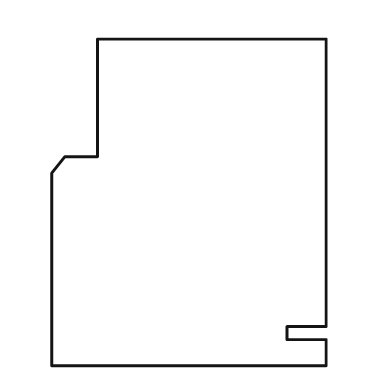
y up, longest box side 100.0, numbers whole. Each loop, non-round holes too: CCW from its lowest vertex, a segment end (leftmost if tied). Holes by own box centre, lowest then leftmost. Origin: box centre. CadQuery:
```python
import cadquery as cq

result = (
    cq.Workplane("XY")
    .moveTo(-42.0, -50.0)
    .lineTo(42.0, -50.0)
    .lineTo(42.0, -42.0)
    .lineTo(30.0, -42.0)
    .lineTo(30.0, -38.0)
    .lineTo(42.0, -38.0)
    .lineTo(42.0, 50.0)
    .lineTo(-28.0, 50.0)
    .lineTo(-28.0, 14.0)
    .lineTo(-38.0, 14.0)
    .lineTo(-42.0, 9.0)
    .close()
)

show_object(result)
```